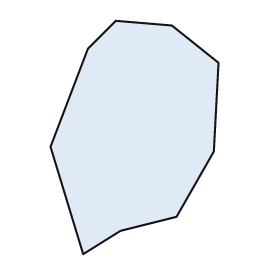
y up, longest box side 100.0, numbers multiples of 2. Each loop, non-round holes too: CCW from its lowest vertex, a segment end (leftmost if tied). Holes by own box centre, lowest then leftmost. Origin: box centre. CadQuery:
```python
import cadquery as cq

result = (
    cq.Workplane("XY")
    .moveTo(-22.0, -50.0)
    .lineTo(-6.0, -40.0)
    .lineTo(18.0, -34.0)
    .lineTo(34.0, -6.0)
    .lineTo(36.0, 32.0)
    .lineTo(16.0, 48.0)
    .lineTo(-8.0, 50.0)
    .lineTo(-20.0, 38.0)
    .lineTo(-36.0, -4.0)
    .close()
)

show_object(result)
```